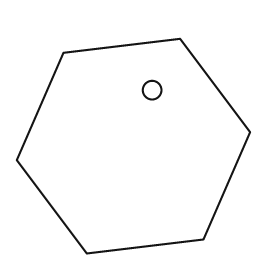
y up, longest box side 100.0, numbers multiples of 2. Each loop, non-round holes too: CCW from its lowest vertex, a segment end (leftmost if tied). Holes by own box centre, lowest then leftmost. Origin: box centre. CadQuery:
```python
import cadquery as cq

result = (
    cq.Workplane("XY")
    .moveTo(-20.0, -46.0)
    .lineTo(30.0, -40.0)
    .lineTo(50.0, 6.0)
    .lineTo(20.0, 46.0)
    .lineTo(-30.0, 40.0)
    .lineTo(-50.0, -6.0)
    .close()
    .moveTo(8.0, 24.0)
    .circle(4.0)
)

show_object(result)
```